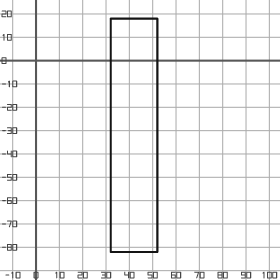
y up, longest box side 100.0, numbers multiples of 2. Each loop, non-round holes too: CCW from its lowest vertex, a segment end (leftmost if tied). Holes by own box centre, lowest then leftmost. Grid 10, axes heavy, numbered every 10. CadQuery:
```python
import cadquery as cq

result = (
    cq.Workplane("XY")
    .moveTo(32.0, -82.0)
    .lineTo(52.0, -82.0)
    .lineTo(52.0, 18.0)
    .lineTo(32.0, 18.0)
    .close()
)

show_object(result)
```